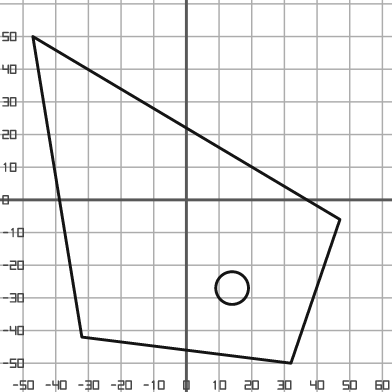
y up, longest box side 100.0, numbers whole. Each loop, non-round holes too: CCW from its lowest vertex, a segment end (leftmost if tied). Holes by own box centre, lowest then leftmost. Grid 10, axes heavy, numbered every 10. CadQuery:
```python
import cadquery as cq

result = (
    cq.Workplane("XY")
    .moveTo(32.0, -50.0)
    .lineTo(47.0, -6.0)
    .lineTo(-47.0, 50.0)
    .lineTo(-32.0, -42.0)
    .close()
    .moveTo(14.0, -27.0)
    .circle(5.0)
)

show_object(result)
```